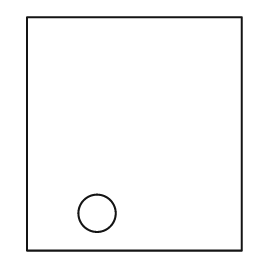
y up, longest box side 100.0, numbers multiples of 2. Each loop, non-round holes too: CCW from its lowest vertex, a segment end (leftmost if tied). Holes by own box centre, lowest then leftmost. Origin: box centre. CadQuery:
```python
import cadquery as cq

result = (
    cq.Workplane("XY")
    .moveTo(-46.0, -50.0)
    .lineTo(46.0, -50.0)
    .lineTo(46.0, 50.0)
    .lineTo(-46.0, 50.0)
    .close()
    .moveTo(-16.0, -34.0)
    .circle(8.0)
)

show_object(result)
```